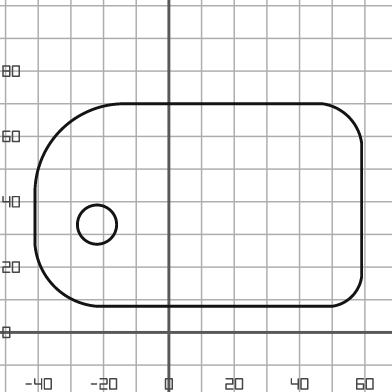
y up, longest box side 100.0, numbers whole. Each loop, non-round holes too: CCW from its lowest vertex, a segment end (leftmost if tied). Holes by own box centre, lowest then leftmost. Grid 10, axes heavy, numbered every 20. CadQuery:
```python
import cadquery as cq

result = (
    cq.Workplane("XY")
    .moveTo(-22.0, 8.0)
    .lineTo(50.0, 8.0)
    .threePointArc((56.0, 11.0), (59.0, 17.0))
    .lineTo(59.0, 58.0)
    .threePointArc((55.0, 66.0), (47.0, 70.0))
    .lineTo(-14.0, 70.0)
    .threePointArc((-33.0, 62.0), (-41.0, 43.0))
    .lineTo(-41.0, 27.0)
    .threePointArc((-35.0, 14.0), (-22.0, 8.0))
    .close()
    .moveTo(-22.0, 33.0)
    .circle(6.0)
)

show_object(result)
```